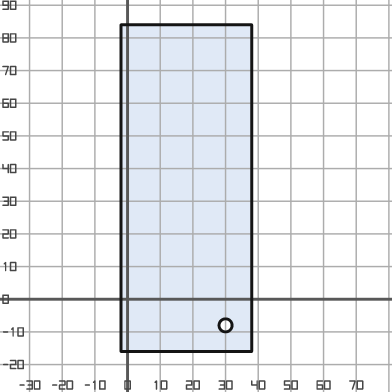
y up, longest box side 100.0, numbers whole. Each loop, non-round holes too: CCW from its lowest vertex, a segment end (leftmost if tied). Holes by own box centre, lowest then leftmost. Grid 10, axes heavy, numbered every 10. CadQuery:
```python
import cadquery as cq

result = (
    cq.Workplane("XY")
    .moveTo(-2.0, -16.0)
    .lineTo(38.0, -16.0)
    .lineTo(38.0, 84.0)
    .lineTo(-2.0, 84.0)
    .close()
    .moveTo(30.0, -8.0)
    .circle(2.0)
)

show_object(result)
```